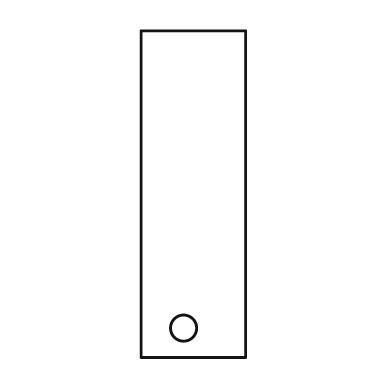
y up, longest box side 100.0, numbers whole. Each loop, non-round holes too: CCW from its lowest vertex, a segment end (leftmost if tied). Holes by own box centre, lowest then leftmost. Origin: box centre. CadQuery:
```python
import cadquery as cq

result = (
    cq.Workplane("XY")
    .moveTo(-16.0, -50.0)
    .lineTo(16.0, -50.0)
    .lineTo(16.0, 50.0)
    .lineTo(-16.0, 50.0)
    .close()
    .moveTo(-3.0, -41.0)
    .circle(4.0)
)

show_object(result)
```